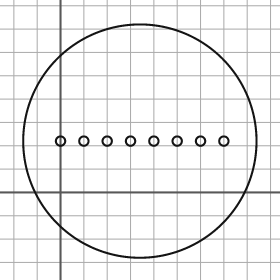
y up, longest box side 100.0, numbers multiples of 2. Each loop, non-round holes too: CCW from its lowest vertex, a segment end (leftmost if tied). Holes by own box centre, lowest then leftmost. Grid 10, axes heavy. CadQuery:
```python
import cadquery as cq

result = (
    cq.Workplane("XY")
    .moveTo(34.0, 22.0)
    .circle(50.0)
    .moveTo(0.0, 22.0)
    .circle(2.0)
    .moveTo(10.0, 22.0)
    .circle(2.0)
    .moveTo(20.0, 22.0)
    .circle(2.0)
    .moveTo(30.0, 22.0)
    .circle(2.0)
    .moveTo(40.0, 22.0)
    .circle(2.0)
    .moveTo(50.0, 22.0)
    .circle(2.0)
    .moveTo(60.0, 22.0)
    .circle(2.0)
    .moveTo(70.0, 22.0)
    .circle(2.0)
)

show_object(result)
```